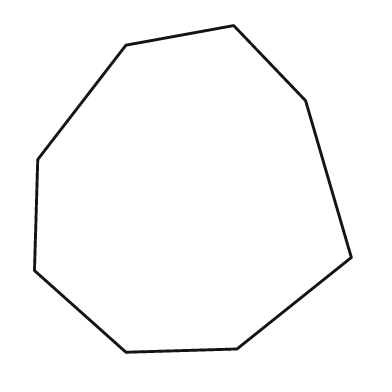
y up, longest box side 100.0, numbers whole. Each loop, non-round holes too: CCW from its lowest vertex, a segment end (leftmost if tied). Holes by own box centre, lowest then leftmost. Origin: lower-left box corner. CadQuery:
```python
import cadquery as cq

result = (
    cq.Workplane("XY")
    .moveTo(28.0, 0.0)
    .lineTo(62.0, 1.0)
    .lineTo(97.0, 29.0)
    .lineTo(83.0, 77.0)
    .lineTo(61.0, 100.0)
    .lineTo(28.0, 94.0)
    .lineTo(1.0, 59.0)
    .lineTo(0.0, 25.0)
    .close()
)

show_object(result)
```